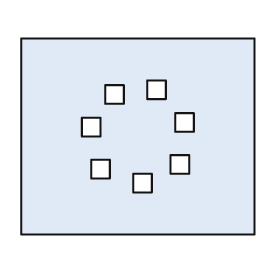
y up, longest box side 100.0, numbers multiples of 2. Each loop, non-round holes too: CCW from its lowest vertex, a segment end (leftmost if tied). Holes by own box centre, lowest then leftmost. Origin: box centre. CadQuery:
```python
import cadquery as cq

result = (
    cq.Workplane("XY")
    .moveTo(-50.0, -42.0)
    .lineTo(50.0, -42.0)
    .lineTo(50.0, 42.0)
    .lineTo(-50.0, 42.0)
    .close()
    .moveTo(-2.0, -24.0)
    .lineTo(6.0, -24.0)
    .lineTo(6.0, -16.0)
    .lineTo(-2.0, -16.0)
    .close()
    .moveTo(-20.0, -18.0)
    .lineTo(-12.0, -18.0)
    .lineTo(-12.0, -10.0)
    .lineTo(-20.0, -10.0)
    .close()
    .moveTo(14.0, -16.0)
    .lineTo(22.0, -16.0)
    .lineTo(22.0, -8.0)
    .lineTo(14.0, -8.0)
    .close()
    .moveTo(-24.0, 0.0)
    .lineTo(-16.0, 0.0)
    .lineTo(-16.0, 8.0)
    .lineTo(-24.0, 8.0)
    .close()
    .moveTo(16.0, 2.0)
    .lineTo(24.0, 2.0)
    .lineTo(24.0, 10.0)
    .lineTo(16.0, 10.0)
    .close()
    .moveTo(-14.0, 14.0)
    .lineTo(-6.0, 14.0)
    .lineTo(-6.0, 22.0)
    .lineTo(-14.0, 22.0)
    .close()
    .moveTo(4.0, 16.0)
    .lineTo(12.0, 16.0)
    .lineTo(12.0, 24.0)
    .lineTo(4.0, 24.0)
    .close()
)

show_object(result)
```